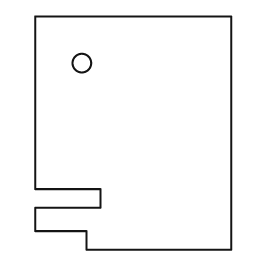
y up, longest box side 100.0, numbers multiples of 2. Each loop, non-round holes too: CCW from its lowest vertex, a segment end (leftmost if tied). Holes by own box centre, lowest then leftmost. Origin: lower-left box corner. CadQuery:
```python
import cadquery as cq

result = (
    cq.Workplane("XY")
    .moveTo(22.0, 0.0)
    .lineTo(84.0, 0.0)
    .lineTo(84.0, 100.0)
    .lineTo(0.0, 100.0)
    .lineTo(0.0, 26.0)
    .lineTo(28.0, 26.0)
    .lineTo(28.0, 18.0)
    .lineTo(0.0, 18.0)
    .lineTo(0.0, 8.0)
    .lineTo(22.0, 8.0)
    .close()
    .moveTo(20.0, 80.0)
    .circle(4.0)
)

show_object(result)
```